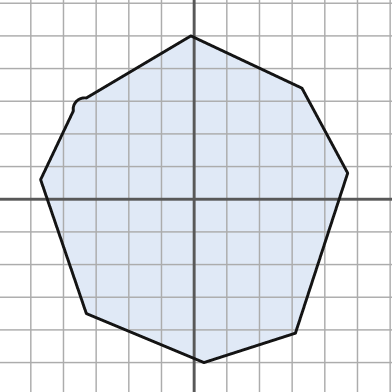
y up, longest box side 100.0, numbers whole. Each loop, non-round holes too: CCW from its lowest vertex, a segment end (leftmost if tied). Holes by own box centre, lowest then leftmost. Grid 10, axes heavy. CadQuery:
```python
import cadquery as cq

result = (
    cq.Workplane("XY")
    .moveTo(3.0, -50.0)
    .lineTo(31.0, -41.0)
    .lineTo(47.0, 8.0)
    .lineTo(33.0, 34.0)
    .lineTo(-1.0, 50.0)
    .lineTo(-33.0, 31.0)
    .threePointArc((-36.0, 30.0), (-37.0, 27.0))
    .lineTo(-47.0, 6.0)
    .lineTo(-33.0, -35.0)
    .close()
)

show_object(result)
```